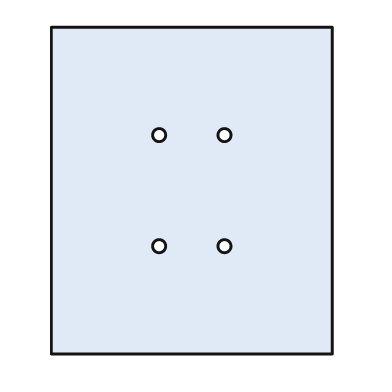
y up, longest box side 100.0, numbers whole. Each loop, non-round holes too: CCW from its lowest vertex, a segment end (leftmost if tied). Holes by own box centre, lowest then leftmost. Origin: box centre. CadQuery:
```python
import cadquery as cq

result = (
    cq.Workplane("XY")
    .moveTo(-43.0, -50.0)
    .lineTo(43.0, -50.0)
    .lineTo(43.0, 50.0)
    .lineTo(-43.0, 50.0)
    .close()
    .moveTo(-10.0, -17.0)
    .circle(2.0)
    .moveTo(10.0, -17.0)
    .circle(2.0)
    .moveTo(-10.0, 17.0)
    .circle(2.0)
    .moveTo(10.0, 17.0)
    .circle(2.0)
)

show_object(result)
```